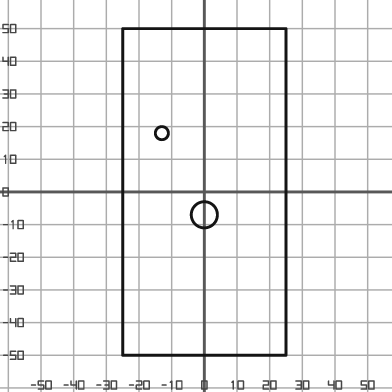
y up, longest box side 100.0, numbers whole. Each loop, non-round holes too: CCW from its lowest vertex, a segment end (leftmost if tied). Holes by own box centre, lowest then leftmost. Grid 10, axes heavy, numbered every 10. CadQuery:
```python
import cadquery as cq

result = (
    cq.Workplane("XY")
    .moveTo(-25.0, -50.0)
    .lineTo(25.0, -50.0)
    .lineTo(25.0, 50.0)
    .lineTo(-25.0, 50.0)
    .close()
    .moveTo(0.0, -7.0)
    .circle(4.0)
    .moveTo(-13.0, 18.0)
    .circle(2.0)
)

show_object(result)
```